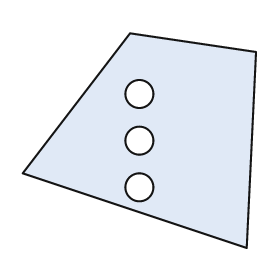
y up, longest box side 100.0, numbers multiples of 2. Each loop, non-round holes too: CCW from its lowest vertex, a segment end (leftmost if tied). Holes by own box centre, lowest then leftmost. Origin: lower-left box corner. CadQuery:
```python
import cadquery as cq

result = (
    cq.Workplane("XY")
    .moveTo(96.0, 0.0)
    .lineTo(100.0, 84.0)
    .lineTo(46.0, 92.0)
    .lineTo(0.0, 32.0)
    .close()
    .moveTo(50.0, 26.0)
    .circle(6.0)
    .moveTo(50.0, 46.0)
    .circle(6.0)
    .moveTo(50.0, 66.0)
    .circle(6.0)
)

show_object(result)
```